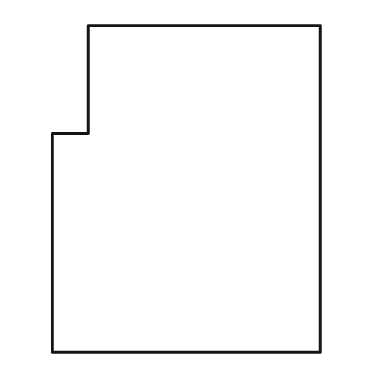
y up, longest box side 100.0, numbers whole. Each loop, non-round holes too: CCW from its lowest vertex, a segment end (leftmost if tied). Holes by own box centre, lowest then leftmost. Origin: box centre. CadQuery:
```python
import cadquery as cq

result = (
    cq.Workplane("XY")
    .moveTo(-41.0, -50.0)
    .lineTo(41.0, -50.0)
    .lineTo(41.0, 50.0)
    .lineTo(-30.0, 50.0)
    .lineTo(-30.0, 17.0)
    .lineTo(-41.0, 17.0)
    .close()
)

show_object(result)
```